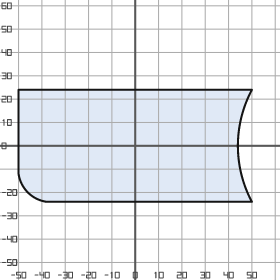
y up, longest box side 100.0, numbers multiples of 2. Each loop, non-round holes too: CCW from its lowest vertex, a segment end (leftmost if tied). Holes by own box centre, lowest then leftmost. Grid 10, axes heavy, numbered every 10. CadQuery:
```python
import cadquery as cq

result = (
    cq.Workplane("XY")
    .moveTo(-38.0, -24.0)
    .lineTo(50.0, -24.0)
    .threePointArc((44.0, 0.0), (50.0, 24.0))
    .lineTo(-50.0, 24.0)
    .lineTo(-50.0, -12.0)
    .threePointArc((-46.0, -20.0), (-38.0, -24.0))
    .close()
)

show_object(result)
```